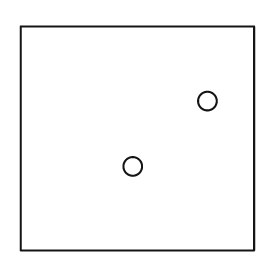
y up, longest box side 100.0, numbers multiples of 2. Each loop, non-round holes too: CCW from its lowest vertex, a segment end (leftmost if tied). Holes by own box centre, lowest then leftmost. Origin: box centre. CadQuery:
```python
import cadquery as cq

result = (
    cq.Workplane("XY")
    .moveTo(-50.0, -48.0)
    .lineTo(50.0, -48.0)
    .lineTo(50.0, 48.0)
    .lineTo(-50.0, 48.0)
    .close()
    .moveTo(-2.0, -12.0)
    .circle(4.0)
    .moveTo(30.0, 16.0)
    .circle(4.0)
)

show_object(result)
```